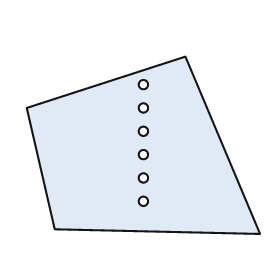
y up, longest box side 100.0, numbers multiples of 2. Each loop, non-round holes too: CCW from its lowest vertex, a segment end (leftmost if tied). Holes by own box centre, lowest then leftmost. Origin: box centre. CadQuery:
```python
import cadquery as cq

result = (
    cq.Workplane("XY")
    .moveTo(50.0, -38.0)
    .lineTo(18.0, 38.0)
    .lineTo(-50.0, 16.0)
    .lineTo(-38.0, -36.0)
    .close()
    .moveTo(0.0, -24.0)
    .circle(2.0)
    .moveTo(0.0, -14.0)
    .circle(2.0)
    .moveTo(0.0, -4.0)
    .circle(2.0)
    .moveTo(0.0, 6.0)
    .circle(2.0)
    .moveTo(0.0, 16.0)
    .circle(2.0)
    .moveTo(0.0, 26.0)
    .circle(2.0)
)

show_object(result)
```